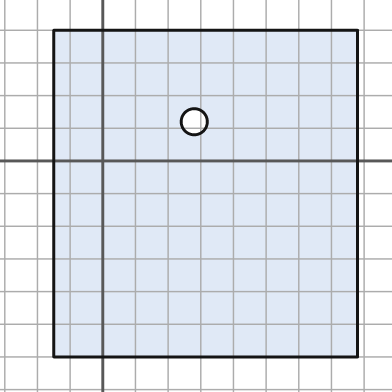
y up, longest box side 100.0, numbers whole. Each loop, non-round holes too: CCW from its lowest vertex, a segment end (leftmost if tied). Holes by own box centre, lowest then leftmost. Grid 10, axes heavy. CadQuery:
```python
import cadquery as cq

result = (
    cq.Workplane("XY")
    .moveTo(-15.0, -60.0)
    .lineTo(78.0, -60.0)
    .lineTo(78.0, 40.0)
    .lineTo(-15.0, 40.0)
    .close()
    .moveTo(28.0, 12.0)
    .circle(4.0)
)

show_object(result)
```